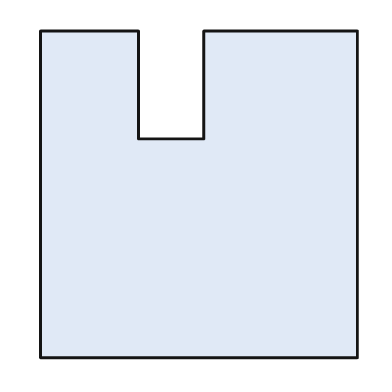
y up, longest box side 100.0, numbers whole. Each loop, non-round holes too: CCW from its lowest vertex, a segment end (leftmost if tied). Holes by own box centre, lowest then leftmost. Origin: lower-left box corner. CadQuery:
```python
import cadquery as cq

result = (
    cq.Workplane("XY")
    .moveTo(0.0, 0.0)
    .lineTo(97.0, 0.0)
    .lineTo(97.0, 100.0)
    .lineTo(50.0, 100.0)
    .lineTo(50.0, 67.0)
    .lineTo(30.0, 67.0)
    .lineTo(30.0, 100.0)
    .lineTo(0.0, 100.0)
    .close()
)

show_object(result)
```